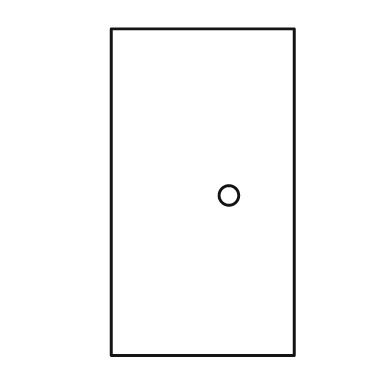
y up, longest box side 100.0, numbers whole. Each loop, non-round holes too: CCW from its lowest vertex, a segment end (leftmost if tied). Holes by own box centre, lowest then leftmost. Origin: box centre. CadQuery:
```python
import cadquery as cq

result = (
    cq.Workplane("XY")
    .moveTo(-28.0, -50.0)
    .lineTo(28.0, -50.0)
    .lineTo(28.0, 50.0)
    .lineTo(-28.0, 50.0)
    .close()
    .moveTo(8.0, -1.0)
    .circle(3.0)
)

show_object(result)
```